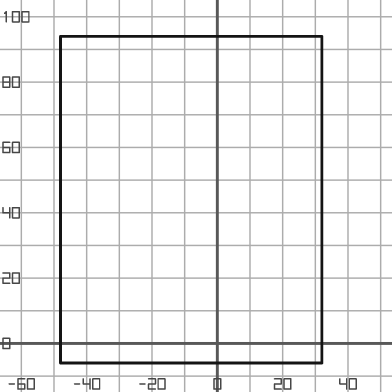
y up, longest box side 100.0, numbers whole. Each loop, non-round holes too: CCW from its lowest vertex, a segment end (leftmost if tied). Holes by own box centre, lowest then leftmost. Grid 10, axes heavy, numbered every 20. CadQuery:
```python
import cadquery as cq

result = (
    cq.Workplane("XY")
    .moveTo(-48.0, -6.0)
    .lineTo(32.0, -6.0)
    .lineTo(32.0, 94.0)
    .lineTo(-48.0, 94.0)
    .close()
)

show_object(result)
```